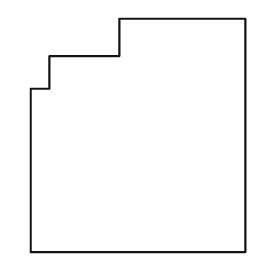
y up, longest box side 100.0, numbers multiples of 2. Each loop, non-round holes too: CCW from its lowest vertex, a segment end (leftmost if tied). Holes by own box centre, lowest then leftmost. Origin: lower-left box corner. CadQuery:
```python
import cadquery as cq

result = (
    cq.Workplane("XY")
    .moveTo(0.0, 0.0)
    .lineTo(92.0, 0.0)
    .lineTo(92.0, 100.0)
    .lineTo(38.0, 100.0)
    .lineTo(38.0, 84.0)
    .lineTo(8.0, 84.0)
    .lineTo(8.0, 70.0)
    .lineTo(0.0, 70.0)
    .close()
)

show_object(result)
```